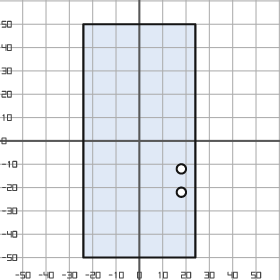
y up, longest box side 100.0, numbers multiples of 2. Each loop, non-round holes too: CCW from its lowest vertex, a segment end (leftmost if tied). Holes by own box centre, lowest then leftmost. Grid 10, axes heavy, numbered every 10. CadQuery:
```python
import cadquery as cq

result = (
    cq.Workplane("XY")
    .moveTo(-24.0, -50.0)
    .lineTo(24.0, -50.0)
    .lineTo(24.0, 50.0)
    .lineTo(-24.0, 50.0)
    .close()
    .moveTo(18.0, -22.0)
    .circle(2.0)
    .moveTo(18.0, -12.0)
    .circle(2.0)
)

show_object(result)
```